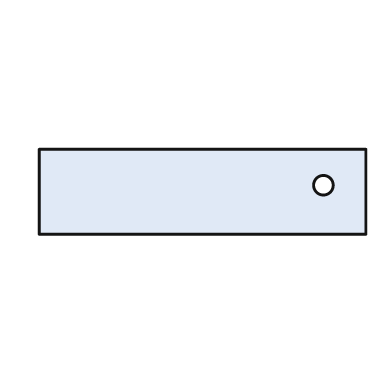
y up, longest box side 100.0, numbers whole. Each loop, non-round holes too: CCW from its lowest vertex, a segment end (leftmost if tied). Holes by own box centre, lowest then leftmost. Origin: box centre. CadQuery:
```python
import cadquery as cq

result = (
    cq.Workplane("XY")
    .moveTo(-50.0, -13.0)
    .lineTo(50.0, -13.0)
    .lineTo(50.0, 13.0)
    .lineTo(-50.0, 13.0)
    .close()
    .moveTo(37.0, 2.0)
    .circle(3.0)
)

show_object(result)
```